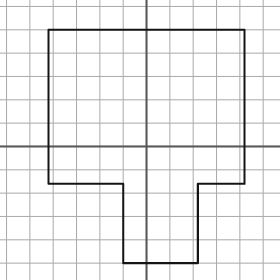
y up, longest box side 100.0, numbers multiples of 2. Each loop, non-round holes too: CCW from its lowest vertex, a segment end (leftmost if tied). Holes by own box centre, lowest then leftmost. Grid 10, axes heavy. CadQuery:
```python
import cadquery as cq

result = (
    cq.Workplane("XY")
    .moveTo(-10.0, -50.0)
    .lineTo(22.0, -50.0)
    .lineTo(22.0, -16.0)
    .lineTo(42.0, -16.0)
    .lineTo(42.0, 50.0)
    .lineTo(-42.0, 50.0)
    .lineTo(-42.0, -16.0)
    .lineTo(-10.0, -16.0)
    .close()
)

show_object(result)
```